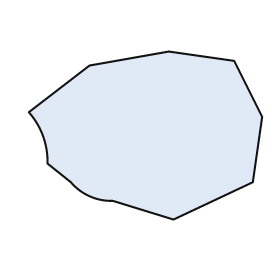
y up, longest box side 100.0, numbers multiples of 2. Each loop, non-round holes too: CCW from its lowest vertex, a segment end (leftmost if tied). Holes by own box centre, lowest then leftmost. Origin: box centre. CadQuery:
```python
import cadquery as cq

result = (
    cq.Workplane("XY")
    .moveTo(12.0, -36.0)
    .lineTo(46.0, -20.0)
    .lineTo(50.0, 8.0)
    .lineTo(38.0, 32.0)
    .lineTo(10.0, 36.0)
    .lineTo(-24.0, 30.0)
    .lineTo(-50.0, 10.0)
    .threePointArc((-44.0, 0.0), (-42.0, -12.0))
    .lineTo(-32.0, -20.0)
    .threePointArc((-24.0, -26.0), (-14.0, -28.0))
    .close()
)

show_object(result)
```